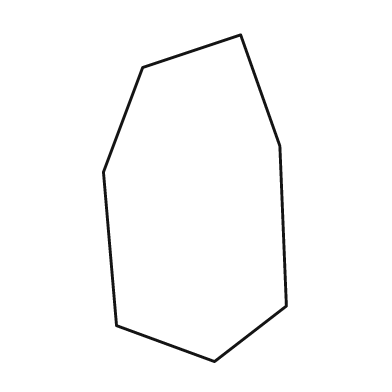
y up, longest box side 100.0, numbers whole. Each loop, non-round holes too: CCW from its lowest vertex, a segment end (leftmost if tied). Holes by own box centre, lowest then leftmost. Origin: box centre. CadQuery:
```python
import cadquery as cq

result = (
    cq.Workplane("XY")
    .moveTo(6.0, -50.0)
    .lineTo(28.0, -33.0)
    .lineTo(26.0, 16.0)
    .lineTo(14.0, 50.0)
    .lineTo(-16.0, 40.0)
    .lineTo(-28.0, 8.0)
    .lineTo(-24.0, -39.0)
    .close()
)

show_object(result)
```